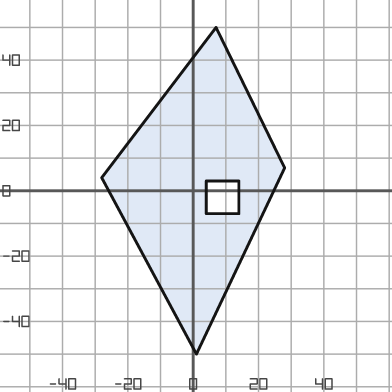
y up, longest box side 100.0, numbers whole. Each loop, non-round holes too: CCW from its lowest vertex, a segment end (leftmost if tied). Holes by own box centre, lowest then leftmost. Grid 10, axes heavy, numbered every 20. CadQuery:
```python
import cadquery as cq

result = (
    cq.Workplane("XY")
    .moveTo(1.0, -50.0)
    .lineTo(28.0, 7.0)
    .lineTo(7.0, 50.0)
    .lineTo(-28.0, 4.0)
    .close()
    .moveTo(4.0, -7.0)
    .lineTo(14.0, -7.0)
    .lineTo(14.0, 3.0)
    .lineTo(4.0, 3.0)
    .close()
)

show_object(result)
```